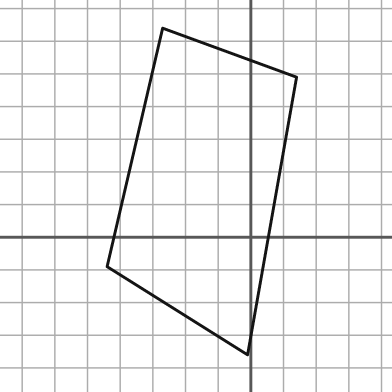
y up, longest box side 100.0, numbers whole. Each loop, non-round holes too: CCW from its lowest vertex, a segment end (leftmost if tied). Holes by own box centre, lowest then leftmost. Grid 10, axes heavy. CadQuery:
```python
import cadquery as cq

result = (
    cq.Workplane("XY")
    .moveTo(-1.0, -36.0)
    .lineTo(14.0, 49.0)
    .lineTo(-27.0, 64.0)
    .lineTo(-44.0, -9.0)
    .close()
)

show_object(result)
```